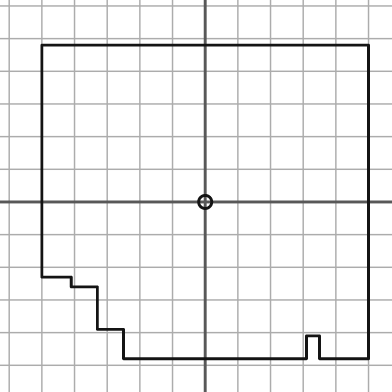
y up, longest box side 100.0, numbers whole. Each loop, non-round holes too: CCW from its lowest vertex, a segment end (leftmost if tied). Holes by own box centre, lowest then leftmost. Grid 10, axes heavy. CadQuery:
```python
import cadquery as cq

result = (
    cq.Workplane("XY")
    .moveTo(-25.0, -48.0)
    .lineTo(31.0, -48.0)
    .lineTo(31.0, -41.0)
    .lineTo(35.0, -41.0)
    .lineTo(35.0, -48.0)
    .lineTo(50.0, -48.0)
    .lineTo(50.0, 48.0)
    .lineTo(-50.0, 48.0)
    .lineTo(-50.0, -23.0)
    .lineTo(-41.0, -23.0)
    .lineTo(-41.0, -26.0)
    .lineTo(-33.0, -26.0)
    .lineTo(-33.0, -39.0)
    .lineTo(-25.0, -39.0)
    .close()
    .moveTo(0.0, 0.0)
    .circle(2.0)
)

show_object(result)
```